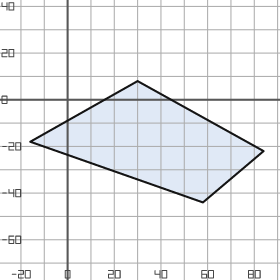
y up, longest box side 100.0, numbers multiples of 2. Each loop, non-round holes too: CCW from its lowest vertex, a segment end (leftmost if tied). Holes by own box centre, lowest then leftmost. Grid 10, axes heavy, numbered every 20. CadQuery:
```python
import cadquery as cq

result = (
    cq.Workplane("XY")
    .moveTo(58.0, -44.0)
    .lineTo(84.0, -22.0)
    .lineTo(30.0, 8.0)
    .lineTo(-16.0, -18.0)
    .close()
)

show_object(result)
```